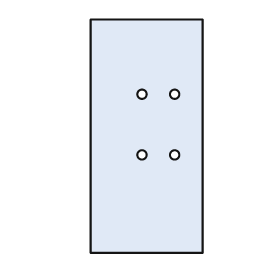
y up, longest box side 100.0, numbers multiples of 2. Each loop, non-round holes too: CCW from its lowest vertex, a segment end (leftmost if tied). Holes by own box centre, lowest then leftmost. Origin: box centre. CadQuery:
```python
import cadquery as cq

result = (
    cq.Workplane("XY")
    .moveTo(-24.0, -50.0)
    .lineTo(24.0, -50.0)
    .lineTo(24.0, 50.0)
    .lineTo(-24.0, 50.0)
    .close()
    .moveTo(-2.0, -8.0)
    .circle(2.0)
    .moveTo(12.0, -8.0)
    .circle(2.0)
    .moveTo(-2.0, 18.0)
    .circle(2.0)
    .moveTo(12.0, 18.0)
    .circle(2.0)
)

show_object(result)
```